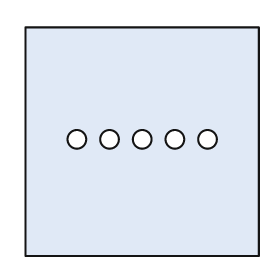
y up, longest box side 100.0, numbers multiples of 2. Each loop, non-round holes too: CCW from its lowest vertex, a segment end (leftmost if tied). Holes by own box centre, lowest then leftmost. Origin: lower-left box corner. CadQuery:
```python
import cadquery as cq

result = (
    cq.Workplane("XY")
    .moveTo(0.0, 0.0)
    .lineTo(100.0, 0.0)
    .lineTo(100.0, 98.0)
    .lineTo(0.0, 98.0)
    .close()
    .moveTo(22.0, 50.0)
    .circle(4.0)
    .moveTo(36.0, 50.0)
    .circle(4.0)
    .moveTo(50.0, 50.0)
    .circle(4.0)
    .moveTo(64.0, 50.0)
    .circle(4.0)
    .moveTo(78.0, 50.0)
    .circle(4.0)
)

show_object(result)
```